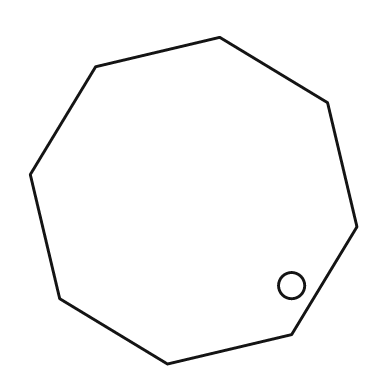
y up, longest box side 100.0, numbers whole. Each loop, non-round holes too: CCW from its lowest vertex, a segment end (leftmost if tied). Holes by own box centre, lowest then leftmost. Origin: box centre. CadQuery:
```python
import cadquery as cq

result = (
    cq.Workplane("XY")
    .moveTo(-8.0, -50.0)
    .lineTo(30.0, -41.0)
    .lineTo(50.0, -8.0)
    .lineTo(41.0, 30.0)
    .lineTo(8.0, 50.0)
    .lineTo(-30.0, 41.0)
    .lineTo(-50.0, 8.0)
    .lineTo(-41.0, -30.0)
    .close()
    .moveTo(30.0, -26.0)
    .circle(4.0)
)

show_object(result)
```